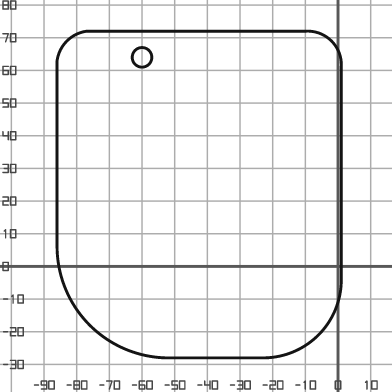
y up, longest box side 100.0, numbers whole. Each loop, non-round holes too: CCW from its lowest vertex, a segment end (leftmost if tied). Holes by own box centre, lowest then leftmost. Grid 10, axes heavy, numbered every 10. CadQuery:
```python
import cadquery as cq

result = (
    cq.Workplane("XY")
    .moveTo(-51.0, -28.0)
    .lineTo(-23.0, -28.0)
    .threePointArc((-6.0, -21.0), (1.0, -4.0))
    .lineTo(1.0, 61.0)
    .threePointArc((-2.0, 69.0), (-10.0, 72.0))
    .lineTo(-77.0, 72.0)
    .threePointArc((-83.0, 69.0), (-86.0, 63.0))
    .lineTo(-86.0, 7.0)
    .threePointArc((-76.0, -18.0), (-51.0, -28.0))
    .close()
    .moveTo(-60.0, 64.0)
    .circle(3.0)
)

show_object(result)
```